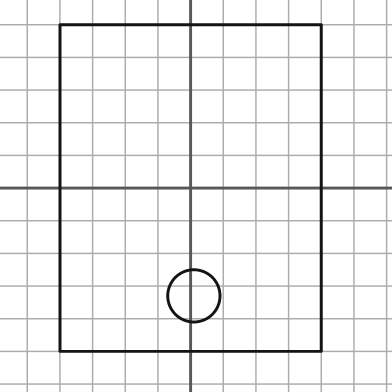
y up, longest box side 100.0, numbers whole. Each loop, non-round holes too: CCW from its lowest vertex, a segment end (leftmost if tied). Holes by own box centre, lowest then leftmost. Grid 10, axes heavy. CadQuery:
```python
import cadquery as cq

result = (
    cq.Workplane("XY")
    .moveTo(-40.0, -50.0)
    .lineTo(40.0, -50.0)
    .lineTo(40.0, 50.0)
    .lineTo(-40.0, 50.0)
    .close()
    .moveTo(1.0, -33.0)
    .circle(8.0)
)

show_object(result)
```